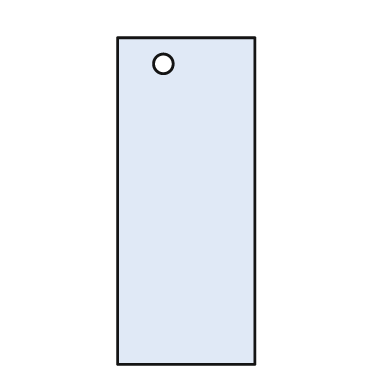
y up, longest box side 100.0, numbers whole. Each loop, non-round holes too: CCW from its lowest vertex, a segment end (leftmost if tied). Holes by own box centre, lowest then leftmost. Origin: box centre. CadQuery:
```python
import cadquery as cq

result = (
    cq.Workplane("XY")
    .moveTo(-21.0, -50.0)
    .lineTo(21.0, -50.0)
    .lineTo(21.0, 50.0)
    .lineTo(-21.0, 50.0)
    .close()
    .moveTo(-7.0, 42.0)
    .circle(3.0)
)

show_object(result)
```